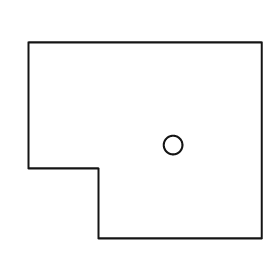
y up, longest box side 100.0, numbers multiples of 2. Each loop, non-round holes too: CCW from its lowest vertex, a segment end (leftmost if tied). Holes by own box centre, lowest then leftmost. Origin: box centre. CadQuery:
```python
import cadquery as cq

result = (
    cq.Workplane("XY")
    .moveTo(-20.0, -42.0)
    .lineTo(50.0, -42.0)
    .lineTo(50.0, 42.0)
    .lineTo(-50.0, 42.0)
    .lineTo(-50.0, -12.0)
    .lineTo(-20.0, -12.0)
    .close()
    .moveTo(12.0, -2.0)
    .circle(4.0)
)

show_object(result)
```